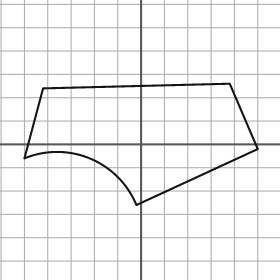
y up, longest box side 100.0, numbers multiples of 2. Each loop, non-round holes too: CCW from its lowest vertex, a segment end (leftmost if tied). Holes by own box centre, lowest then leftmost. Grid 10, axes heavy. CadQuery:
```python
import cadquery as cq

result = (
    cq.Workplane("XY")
    .moveTo(-2.0, -26.0)
    .lineTo(50.0, -2.0)
    .lineTo(38.0, 26.0)
    .lineTo(-42.0, 24.0)
    .lineTo(-50.0, -6.0)
    .threePointArc((-22.0, -6.0), (-2.0, -26.0))
    .close()
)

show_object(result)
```